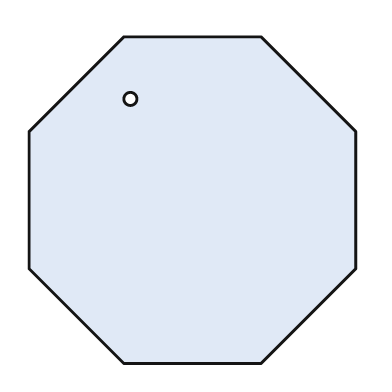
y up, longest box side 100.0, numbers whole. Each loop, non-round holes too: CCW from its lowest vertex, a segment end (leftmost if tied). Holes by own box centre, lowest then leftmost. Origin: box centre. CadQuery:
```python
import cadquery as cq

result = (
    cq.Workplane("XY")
    .moveTo(-21.0, -50.0)
    .lineTo(21.0, -50.0)
    .lineTo(50.0, -21.0)
    .lineTo(50.0, 21.0)
    .lineTo(21.0, 50.0)
    .lineTo(-21.0, 50.0)
    .lineTo(-50.0, 21.0)
    .lineTo(-50.0, -21.0)
    .close()
    .moveTo(-19.0, 31.0)
    .circle(2.0)
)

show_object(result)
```